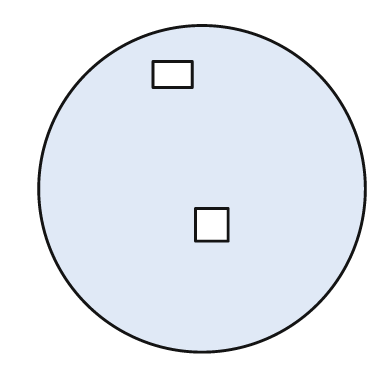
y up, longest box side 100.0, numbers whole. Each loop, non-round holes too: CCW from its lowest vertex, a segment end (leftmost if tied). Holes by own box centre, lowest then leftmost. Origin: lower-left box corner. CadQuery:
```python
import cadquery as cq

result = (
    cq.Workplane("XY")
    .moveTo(50.0, 50.0)
    .circle(50.0)
    .moveTo(48.0, 34.0)
    .lineTo(58.0, 34.0)
    .lineTo(58.0, 44.0)
    .lineTo(48.0, 44.0)
    .close()
    .moveTo(35.0, 81.0)
    .lineTo(47.0, 81.0)
    .lineTo(47.0, 89.0)
    .lineTo(35.0, 89.0)
    .close()
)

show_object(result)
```